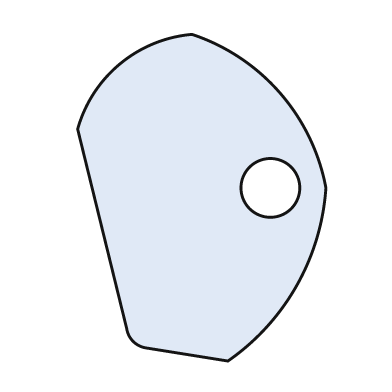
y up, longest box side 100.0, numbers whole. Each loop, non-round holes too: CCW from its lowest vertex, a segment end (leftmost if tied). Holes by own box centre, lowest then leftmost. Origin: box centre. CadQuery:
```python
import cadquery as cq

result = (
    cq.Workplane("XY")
    .moveTo(8.0, -50.0)
    .threePointArc((29.0, -27.0), (38.0, 3.0))
    .threePointArc((24.0, 32.0), (-3.0, 50.0))
    .threePointArc((-25.0, 41.0), (-38.0, 21.0))
    .lineTo(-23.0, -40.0)
    .threePointArc((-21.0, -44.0), (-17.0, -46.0))
    .close()
    .moveTo(21.0, 3.0)
    .circle(9.0)
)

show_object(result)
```